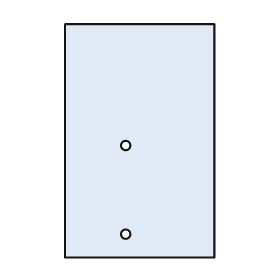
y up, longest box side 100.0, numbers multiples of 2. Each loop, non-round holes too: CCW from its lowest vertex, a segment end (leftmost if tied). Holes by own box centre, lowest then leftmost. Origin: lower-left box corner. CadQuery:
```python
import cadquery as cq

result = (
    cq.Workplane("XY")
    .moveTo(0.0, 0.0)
    .lineTo(64.0, 0.0)
    .lineTo(64.0, 100.0)
    .lineTo(0.0, 100.0)
    .close()
    .moveTo(26.0, 10.0)
    .circle(2.0)
    .moveTo(26.0, 48.0)
    .circle(2.0)
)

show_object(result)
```